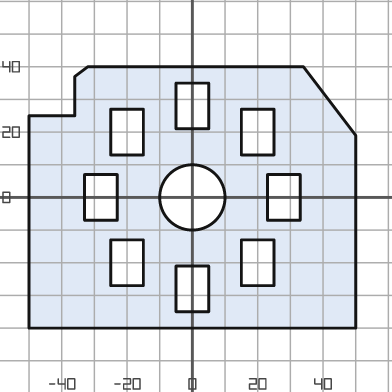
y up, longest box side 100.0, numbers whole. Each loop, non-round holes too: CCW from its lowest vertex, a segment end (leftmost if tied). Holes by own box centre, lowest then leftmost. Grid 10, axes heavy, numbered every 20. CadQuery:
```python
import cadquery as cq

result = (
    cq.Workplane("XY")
    .moveTo(-50.0, -40.0)
    .lineTo(50.0, -40.0)
    .lineTo(50.0, 19.0)
    .lineTo(34.0, 40.0)
    .lineTo(-32.0, 40.0)
    .lineTo(-36.0, 37.0)
    .lineTo(-36.0, 25.0)
    .lineTo(-50.0, 25.0)
    .close()
    .moveTo(-5.0, -35.0)
    .lineTo(5.0, -35.0)
    .lineTo(5.0, -21.0)
    .lineTo(-5.0, -21.0)
    .close()
    .moveTo(-25.0, -27.0)
    .lineTo(-15.0, -27.0)
    .lineTo(-15.0, -13.0)
    .lineTo(-25.0, -13.0)
    .close()
    .moveTo(15.0, -27.0)
    .lineTo(25.0, -27.0)
    .lineTo(25.0, -13.0)
    .lineTo(15.0, -13.0)
    .close()
    .moveTo(-33.0, -7.0)
    .lineTo(-23.0, -7.0)
    .lineTo(-23.0, 7.0)
    .lineTo(-33.0, 7.0)
    .close()
    .moveTo(0.0, 0.0)
    .circle(10.0)
    .moveTo(23.0, -7.0)
    .lineTo(33.0, -7.0)
    .lineTo(33.0, 7.0)
    .lineTo(23.0, 7.0)
    .close()
    .moveTo(-25.0, 13.0)
    .lineTo(-15.0, 13.0)
    .lineTo(-15.0, 27.0)
    .lineTo(-25.0, 27.0)
    .close()
    .moveTo(15.0, 13.0)
    .lineTo(25.0, 13.0)
    .lineTo(25.0, 27.0)
    .lineTo(15.0, 27.0)
    .close()
    .moveTo(-5.0, 21.0)
    .lineTo(5.0, 21.0)
    .lineTo(5.0, 35.0)
    .lineTo(-5.0, 35.0)
    .close()
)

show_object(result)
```